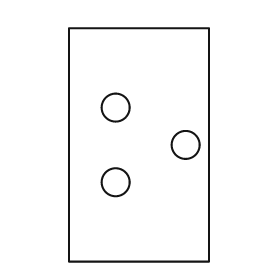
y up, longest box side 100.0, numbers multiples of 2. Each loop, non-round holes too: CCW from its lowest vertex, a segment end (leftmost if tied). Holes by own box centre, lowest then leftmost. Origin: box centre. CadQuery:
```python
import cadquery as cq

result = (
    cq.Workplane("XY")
    .moveTo(-30.0, -50.0)
    .lineTo(30.0, -50.0)
    .lineTo(30.0, 50.0)
    .lineTo(-30.0, 50.0)
    .close()
    .moveTo(-10.0, -16.0)
    .circle(6.0)
    .moveTo(20.0, 0.0)
    .circle(6.0)
    .moveTo(-10.0, 16.0)
    .circle(6.0)
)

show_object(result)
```